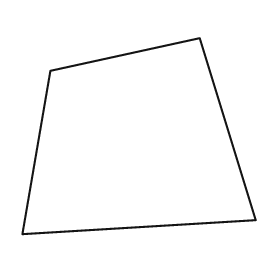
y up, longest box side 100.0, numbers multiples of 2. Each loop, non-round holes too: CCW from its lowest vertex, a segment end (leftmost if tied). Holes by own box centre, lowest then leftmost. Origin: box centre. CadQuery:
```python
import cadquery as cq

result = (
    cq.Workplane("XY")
    .moveTo(-50.0, -42.0)
    .lineTo(50.0, -36.0)
    .lineTo(26.0, 42.0)
    .lineTo(-38.0, 28.0)
    .close()
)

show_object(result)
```